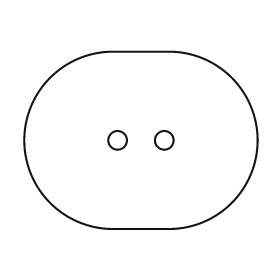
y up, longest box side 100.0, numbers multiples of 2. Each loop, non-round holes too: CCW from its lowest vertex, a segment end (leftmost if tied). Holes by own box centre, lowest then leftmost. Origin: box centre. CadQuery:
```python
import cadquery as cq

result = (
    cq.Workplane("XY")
    .moveTo(-12.0, -38.0)
    .lineTo(12.0, -38.0)
    .threePointArc((50.0, 0.0), (12.0, 38.0))
    .lineTo(-12.0, 38.0)
    .threePointArc((-50.0, 0.0), (-12.0, -38.0))
    .close()
    .moveTo(-10.0, 0.0)
    .circle(4.0)
    .moveTo(10.0, 0.0)
    .circle(4.0)
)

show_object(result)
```